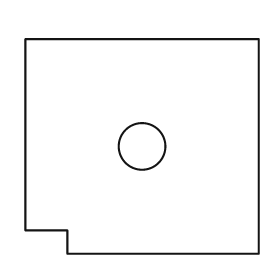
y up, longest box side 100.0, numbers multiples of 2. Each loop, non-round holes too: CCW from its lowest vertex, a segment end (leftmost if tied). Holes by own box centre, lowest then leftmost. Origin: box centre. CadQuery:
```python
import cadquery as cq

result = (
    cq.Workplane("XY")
    .moveTo(-32.0, -46.0)
    .lineTo(50.0, -46.0)
    .lineTo(50.0, 46.0)
    .lineTo(-50.0, 46.0)
    .lineTo(-50.0, -36.0)
    .lineTo(-32.0, -36.0)
    .close()
    .moveTo(0.0, 0.0)
    .circle(10.0)
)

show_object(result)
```